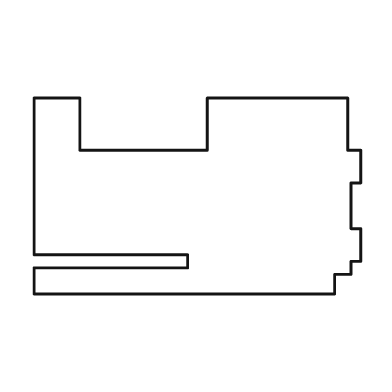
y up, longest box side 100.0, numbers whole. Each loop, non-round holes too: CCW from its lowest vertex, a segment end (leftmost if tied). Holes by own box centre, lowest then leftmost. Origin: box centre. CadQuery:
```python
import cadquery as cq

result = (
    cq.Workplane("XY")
    .moveTo(-50.0, -30.0)
    .lineTo(42.0, -30.0)
    .lineTo(42.0, -24.0)
    .lineTo(47.0, -24.0)
    .lineTo(47.0, -20.0)
    .lineTo(50.0, -20.0)
    .lineTo(50.0, -10.0)
    .lineTo(47.0, -10.0)
    .lineTo(47.0, 4.0)
    .lineTo(50.0, 4.0)
    .lineTo(50.0, 14.0)
    .lineTo(46.0, 14.0)
    .lineTo(46.0, 30.0)
    .lineTo(3.0, 30.0)
    .lineTo(3.0, 14.0)
    .lineTo(-36.0, 14.0)
    .lineTo(-36.0, 30.0)
    .lineTo(-50.0, 30.0)
    .lineTo(-50.0, -18.0)
    .lineTo(-3.0, -18.0)
    .lineTo(-3.0, -22.0)
    .lineTo(-50.0, -22.0)
    .close()
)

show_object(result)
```